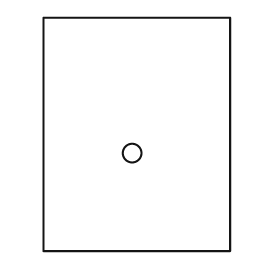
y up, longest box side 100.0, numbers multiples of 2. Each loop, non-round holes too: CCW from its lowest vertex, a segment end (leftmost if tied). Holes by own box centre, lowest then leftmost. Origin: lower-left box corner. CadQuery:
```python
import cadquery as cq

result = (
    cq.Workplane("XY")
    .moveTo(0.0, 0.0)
    .lineTo(80.0, 0.0)
    .lineTo(80.0, 100.0)
    .lineTo(0.0, 100.0)
    .close()
    .moveTo(38.0, 42.0)
    .circle(4.0)
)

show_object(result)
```